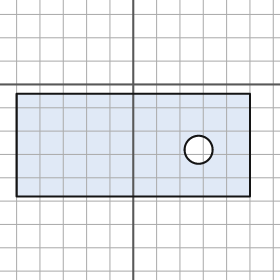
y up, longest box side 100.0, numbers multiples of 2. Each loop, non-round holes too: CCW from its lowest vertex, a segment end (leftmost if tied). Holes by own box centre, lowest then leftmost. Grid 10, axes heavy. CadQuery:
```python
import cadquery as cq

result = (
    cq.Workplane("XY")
    .moveTo(-50.0, -48.0)
    .lineTo(50.0, -48.0)
    .lineTo(50.0, -4.0)
    .lineTo(-50.0, -4.0)
    .close()
    .moveTo(28.0, -28.0)
    .circle(6.0)
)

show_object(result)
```